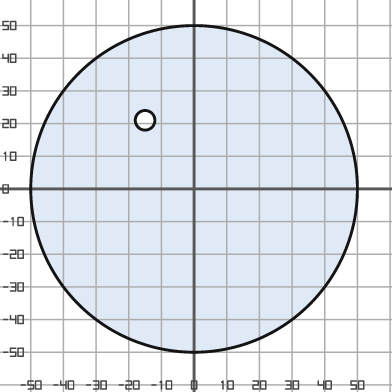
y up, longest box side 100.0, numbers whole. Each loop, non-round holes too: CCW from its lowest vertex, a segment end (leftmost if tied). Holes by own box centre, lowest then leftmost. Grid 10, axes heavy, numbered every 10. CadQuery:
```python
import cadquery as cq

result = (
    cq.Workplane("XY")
    .moveTo(0.0, 0.0)
    .circle(50.0)
    .moveTo(-15.0, 21.0)
    .circle(3.0)
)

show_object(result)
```